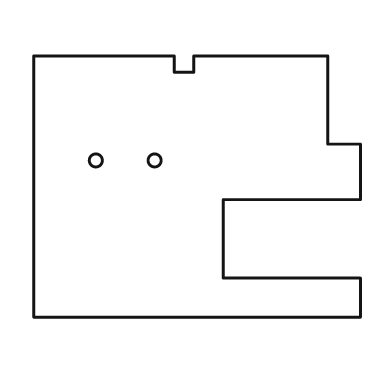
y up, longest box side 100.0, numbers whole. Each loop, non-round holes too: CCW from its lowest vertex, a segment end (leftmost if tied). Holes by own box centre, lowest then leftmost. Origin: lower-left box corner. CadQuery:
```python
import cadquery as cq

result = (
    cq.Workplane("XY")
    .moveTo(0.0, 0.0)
    .lineTo(100.0, 0.0)
    .lineTo(100.0, 12.0)
    .lineTo(58.0, 12.0)
    .lineTo(58.0, 36.0)
    .lineTo(100.0, 36.0)
    .lineTo(100.0, 53.0)
    .lineTo(90.0, 53.0)
    .lineTo(90.0, 80.0)
    .lineTo(49.0, 80.0)
    .lineTo(49.0, 75.0)
    .lineTo(43.0, 75.0)
    .lineTo(43.0, 80.0)
    .lineTo(0.0, 80.0)
    .close()
    .moveTo(19.0, 48.0)
    .circle(2.0)
    .moveTo(37.0, 48.0)
    .circle(2.0)
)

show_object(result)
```